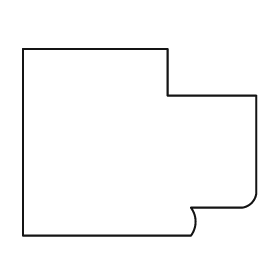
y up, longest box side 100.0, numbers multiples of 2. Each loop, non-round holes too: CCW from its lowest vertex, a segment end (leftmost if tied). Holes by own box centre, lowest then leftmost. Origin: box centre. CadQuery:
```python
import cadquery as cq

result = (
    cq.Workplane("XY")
    .moveTo(-50.0, -40.0)
    .lineTo(22.0, -40.0)
    .threePointArc((24.0, -34.0), (22.0, -28.0))
    .lineTo(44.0, -28.0)
    .threePointArc((48.0, -26.0), (50.0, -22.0))
    .lineTo(50.0, 20.0)
    .lineTo(12.0, 20.0)
    .lineTo(12.0, 40.0)
    .lineTo(-50.0, 40.0)
    .close()
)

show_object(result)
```